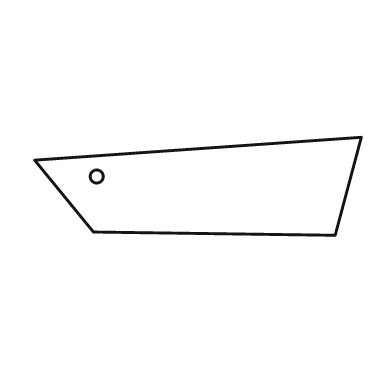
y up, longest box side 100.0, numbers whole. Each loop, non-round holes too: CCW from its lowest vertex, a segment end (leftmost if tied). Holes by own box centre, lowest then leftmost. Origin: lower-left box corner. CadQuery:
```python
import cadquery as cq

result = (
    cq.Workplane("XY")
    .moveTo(92.0, 0.0)
    .lineTo(100.0, 30.0)
    .lineTo(0.0, 23.0)
    .lineTo(18.0, 1.0)
    .close()
    .moveTo(19.0, 18.0)
    .circle(2.0)
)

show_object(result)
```